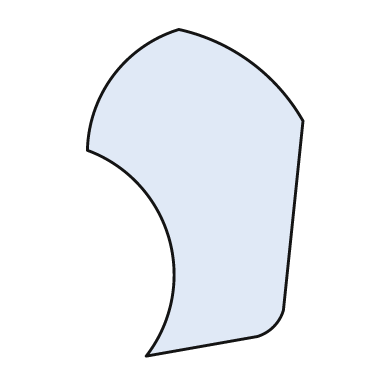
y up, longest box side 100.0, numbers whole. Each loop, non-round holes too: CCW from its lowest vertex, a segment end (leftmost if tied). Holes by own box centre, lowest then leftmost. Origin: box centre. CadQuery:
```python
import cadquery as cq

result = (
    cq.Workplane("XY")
    .moveTo(-15.0, -50.0)
    .lineTo(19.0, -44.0)
    .threePointArc((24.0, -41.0), (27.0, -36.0))
    .lineTo(33.0, 22.0)
    .threePointArc((17.0, 40.0), (-5.0, 50.0))
    .threePointArc((-25.0, 36.0), (-33.0, 13.0))
    .threePointArc((-8.0, -14.0), (-15.0, -50.0))
    .close()
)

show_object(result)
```